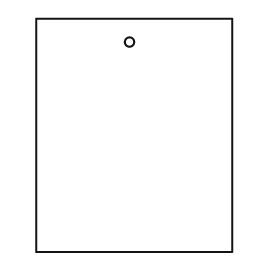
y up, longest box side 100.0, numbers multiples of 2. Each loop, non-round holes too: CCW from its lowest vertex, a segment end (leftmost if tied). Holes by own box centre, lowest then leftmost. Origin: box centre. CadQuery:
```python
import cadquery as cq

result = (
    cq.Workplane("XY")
    .moveTo(-42.0, -50.0)
    .lineTo(42.0, -50.0)
    .lineTo(42.0, 50.0)
    .lineTo(-42.0, 50.0)
    .close()
    .moveTo(-2.0, 40.0)
    .circle(2.0)
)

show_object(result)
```